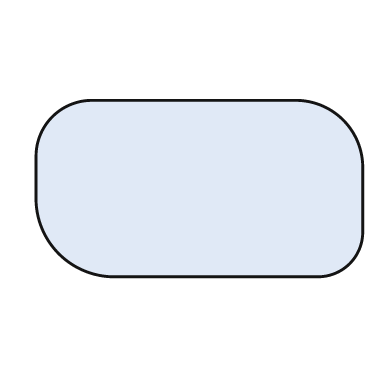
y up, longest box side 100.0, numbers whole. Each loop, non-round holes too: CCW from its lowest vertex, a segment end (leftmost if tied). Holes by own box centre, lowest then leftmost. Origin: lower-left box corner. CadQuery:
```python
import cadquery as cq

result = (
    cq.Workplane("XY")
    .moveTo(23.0, 0.0)
    .lineTo(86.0, 0.0)
    .threePointArc((96.0, 4.0), (100.0, 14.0))
    .lineTo(100.0, 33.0)
    .threePointArc((94.0, 48.0), (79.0, 54.0))
    .lineTo(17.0, 54.0)
    .threePointArc((5.0, 49.0), (0.0, 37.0))
    .lineTo(0.0, 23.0)
    .threePointArc((7.0, 7.0), (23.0, 0.0))
    .close()
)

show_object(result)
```